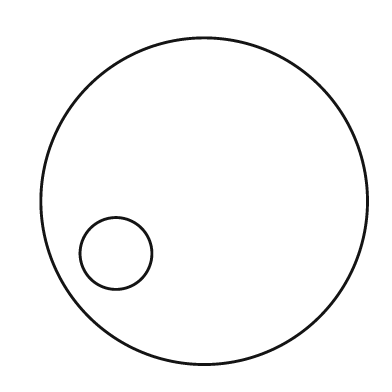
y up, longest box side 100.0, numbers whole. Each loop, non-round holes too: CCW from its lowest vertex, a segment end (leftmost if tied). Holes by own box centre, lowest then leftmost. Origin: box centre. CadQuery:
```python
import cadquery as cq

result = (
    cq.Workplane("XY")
    .moveTo(0.0, 0.0)
    .circle(50.0)
    .moveTo(-27.0, -16.0)
    .circle(11.0)
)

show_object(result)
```